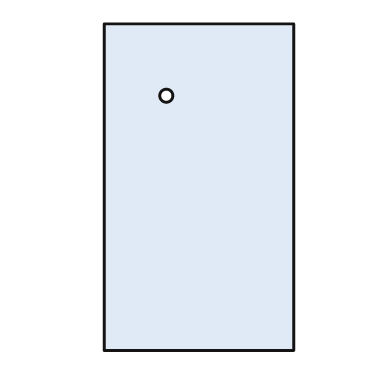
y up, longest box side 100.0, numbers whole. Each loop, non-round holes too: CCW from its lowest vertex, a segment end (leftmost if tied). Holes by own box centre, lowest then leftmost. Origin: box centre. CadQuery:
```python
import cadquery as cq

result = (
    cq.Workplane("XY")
    .moveTo(-29.0, -50.0)
    .lineTo(29.0, -50.0)
    .lineTo(29.0, 50.0)
    .lineTo(-29.0, 50.0)
    .close()
    .moveTo(-10.0, 28.0)
    .circle(2.0)
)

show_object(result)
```